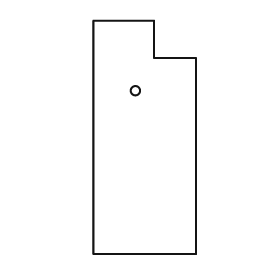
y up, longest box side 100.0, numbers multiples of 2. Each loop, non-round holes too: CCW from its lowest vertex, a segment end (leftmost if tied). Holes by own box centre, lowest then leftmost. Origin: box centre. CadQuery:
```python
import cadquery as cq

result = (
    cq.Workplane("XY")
    .moveTo(-22.0, -50.0)
    .lineTo(22.0, -50.0)
    .lineTo(22.0, 34.0)
    .lineTo(4.0, 34.0)
    .lineTo(4.0, 50.0)
    .lineTo(-22.0, 50.0)
    .close()
    .moveTo(-4.0, 20.0)
    .circle(2.0)
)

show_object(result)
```